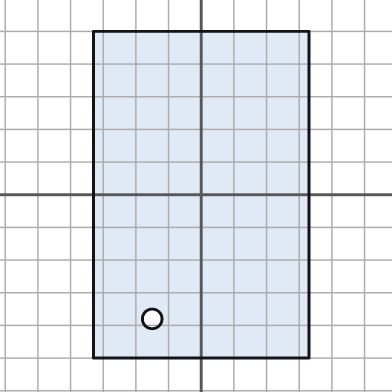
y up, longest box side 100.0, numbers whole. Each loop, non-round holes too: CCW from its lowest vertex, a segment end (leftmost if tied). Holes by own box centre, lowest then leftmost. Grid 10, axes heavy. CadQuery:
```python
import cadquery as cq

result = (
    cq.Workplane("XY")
    .moveTo(-33.0, -50.0)
    .lineTo(33.0, -50.0)
    .lineTo(33.0, 50.0)
    .lineTo(-33.0, 50.0)
    .close()
    .moveTo(-15.0, -38.0)
    .circle(3.0)
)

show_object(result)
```